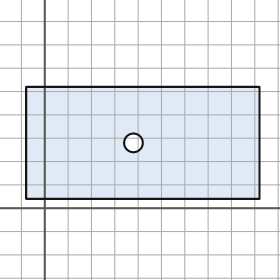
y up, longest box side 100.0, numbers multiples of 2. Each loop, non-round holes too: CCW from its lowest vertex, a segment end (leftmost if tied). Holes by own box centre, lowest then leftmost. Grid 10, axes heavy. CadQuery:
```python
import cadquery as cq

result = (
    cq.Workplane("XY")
    .moveTo(-8.0, 4.0)
    .lineTo(92.0, 4.0)
    .lineTo(92.0, 52.0)
    .lineTo(-8.0, 52.0)
    .close()
    .moveTo(38.0, 28.0)
    .circle(4.0)
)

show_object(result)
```